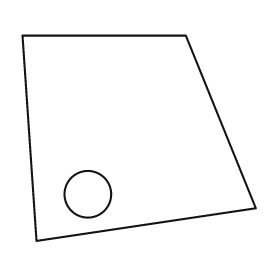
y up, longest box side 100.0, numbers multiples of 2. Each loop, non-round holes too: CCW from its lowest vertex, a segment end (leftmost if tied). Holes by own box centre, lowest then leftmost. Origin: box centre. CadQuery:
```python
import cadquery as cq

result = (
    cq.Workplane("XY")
    .moveTo(-44.0, -44.0)
    .lineTo(50.0, -30.0)
    .lineTo(20.0, 44.0)
    .lineTo(-50.0, 44.0)
    .close()
    .moveTo(-22.0, -24.0)
    .circle(10.0)
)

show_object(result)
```